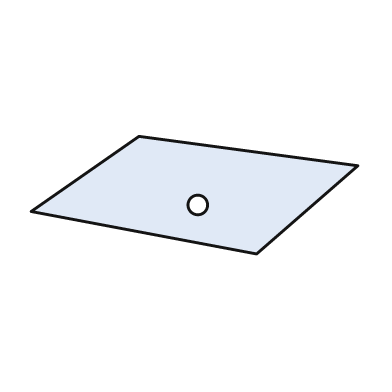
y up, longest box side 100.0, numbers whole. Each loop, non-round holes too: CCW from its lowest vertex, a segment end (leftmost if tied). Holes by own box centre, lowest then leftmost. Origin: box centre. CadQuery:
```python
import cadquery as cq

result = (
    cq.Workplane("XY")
    .moveTo(19.0, -18.0)
    .lineTo(50.0, 9.0)
    .lineTo(-17.0, 18.0)
    .lineTo(-50.0, -5.0)
    .close()
    .moveTo(1.0, -3.0)
    .circle(3.0)
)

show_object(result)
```